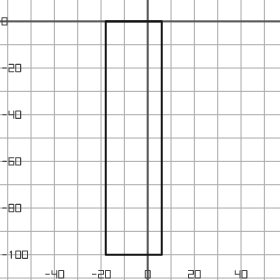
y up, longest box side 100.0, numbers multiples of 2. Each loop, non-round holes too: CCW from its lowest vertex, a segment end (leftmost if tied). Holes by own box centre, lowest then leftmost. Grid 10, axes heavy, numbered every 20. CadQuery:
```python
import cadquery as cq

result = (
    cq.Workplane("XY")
    .moveTo(-18.0, -100.0)
    .lineTo(6.0, -100.0)
    .lineTo(6.0, 0.0)
    .lineTo(-18.0, 0.0)
    .close()
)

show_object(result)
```